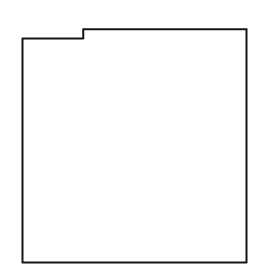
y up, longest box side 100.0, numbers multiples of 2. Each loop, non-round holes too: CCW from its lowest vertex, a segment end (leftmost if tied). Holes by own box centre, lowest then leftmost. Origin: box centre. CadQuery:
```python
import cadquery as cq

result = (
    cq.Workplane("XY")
    .moveTo(-48.0, -50.0)
    .lineTo(48.0, -50.0)
    .lineTo(48.0, 50.0)
    .lineTo(-22.0, 50.0)
    .lineTo(-22.0, 46.0)
    .lineTo(-48.0, 46.0)
    .close()
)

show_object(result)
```